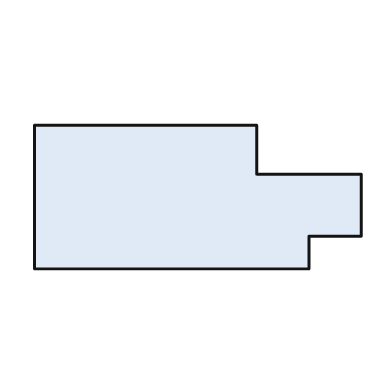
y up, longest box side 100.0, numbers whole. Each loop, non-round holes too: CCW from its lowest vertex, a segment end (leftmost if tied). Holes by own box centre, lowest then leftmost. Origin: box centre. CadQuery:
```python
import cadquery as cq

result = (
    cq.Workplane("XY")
    .moveTo(-50.0, -22.0)
    .lineTo(34.0, -22.0)
    .lineTo(34.0, -12.0)
    .lineTo(50.0, -12.0)
    .lineTo(50.0, 7.0)
    .lineTo(18.0, 7.0)
    .lineTo(18.0, 22.0)
    .lineTo(-50.0, 22.0)
    .close()
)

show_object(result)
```